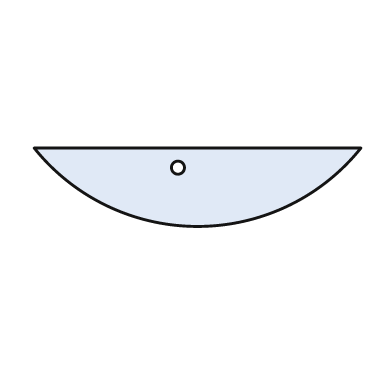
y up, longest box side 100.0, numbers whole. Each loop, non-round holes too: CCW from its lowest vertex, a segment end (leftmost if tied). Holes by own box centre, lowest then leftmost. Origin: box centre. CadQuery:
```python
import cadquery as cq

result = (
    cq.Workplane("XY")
    .moveTo(-50.0, 12.0)
    .threePointArc((0.0, -12.0), (50.0, 12.0))
    .close()
    .moveTo(-6.0, 6.0)
    .circle(2.0)
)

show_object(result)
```